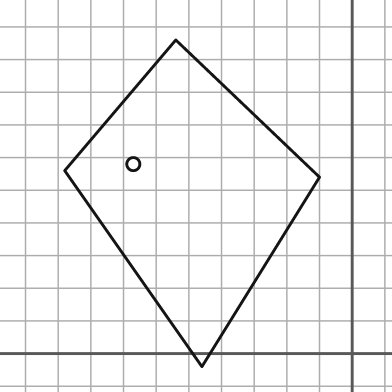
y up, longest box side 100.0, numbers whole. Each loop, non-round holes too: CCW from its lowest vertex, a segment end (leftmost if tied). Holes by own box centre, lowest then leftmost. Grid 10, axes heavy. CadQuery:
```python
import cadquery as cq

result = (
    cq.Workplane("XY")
    .moveTo(-46.0, -4.0)
    .lineTo(-10.0, 54.0)
    .lineTo(-54.0, 96.0)
    .lineTo(-88.0, 56.0)
    .close()
    .moveTo(-67.0, 58.0)
    .circle(2.0)
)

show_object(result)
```